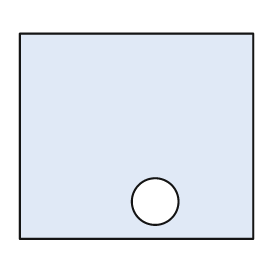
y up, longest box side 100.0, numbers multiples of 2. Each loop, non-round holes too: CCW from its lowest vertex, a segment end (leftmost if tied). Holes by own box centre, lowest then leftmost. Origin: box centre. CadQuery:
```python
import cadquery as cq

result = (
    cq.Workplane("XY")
    .moveTo(-50.0, -44.0)
    .lineTo(50.0, -44.0)
    .lineTo(50.0, 44.0)
    .lineTo(-50.0, 44.0)
    .close()
    .moveTo(8.0, -28.0)
    .circle(10.0)
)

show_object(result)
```